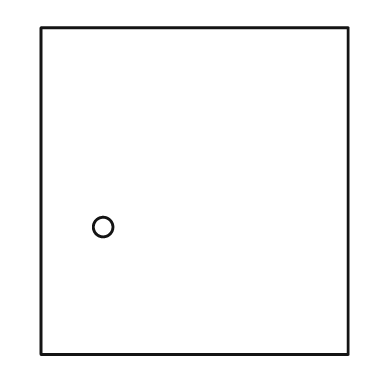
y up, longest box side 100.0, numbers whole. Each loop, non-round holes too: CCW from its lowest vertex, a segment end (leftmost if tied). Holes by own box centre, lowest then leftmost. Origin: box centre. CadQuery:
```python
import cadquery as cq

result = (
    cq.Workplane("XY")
    .moveTo(-47.0, -50.0)
    .lineTo(47.0, -50.0)
    .lineTo(47.0, 50.0)
    .lineTo(-47.0, 50.0)
    .close()
    .moveTo(-28.0, -11.0)
    .circle(3.0)
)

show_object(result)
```